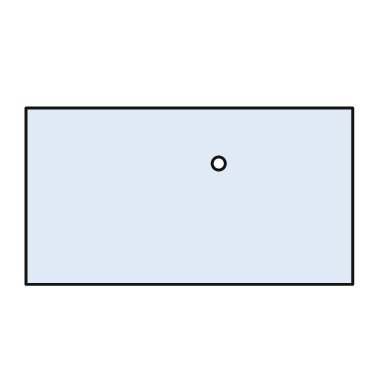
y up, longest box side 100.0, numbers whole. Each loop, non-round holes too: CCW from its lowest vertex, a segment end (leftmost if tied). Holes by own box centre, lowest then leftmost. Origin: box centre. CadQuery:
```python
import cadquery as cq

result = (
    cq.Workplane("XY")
    .moveTo(-50.0, -27.0)
    .lineTo(50.0, -27.0)
    .lineTo(50.0, 27.0)
    .lineTo(-50.0, 27.0)
    .close()
    .moveTo(9.0, 10.0)
    .circle(2.0)
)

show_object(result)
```